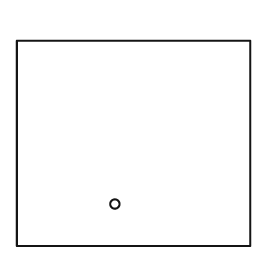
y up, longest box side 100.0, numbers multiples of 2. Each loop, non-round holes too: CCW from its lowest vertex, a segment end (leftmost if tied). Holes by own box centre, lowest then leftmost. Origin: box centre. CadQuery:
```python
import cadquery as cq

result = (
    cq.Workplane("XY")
    .moveTo(-50.0, -44.0)
    .lineTo(50.0, -44.0)
    .lineTo(50.0, 44.0)
    .lineTo(-50.0, 44.0)
    .close()
    .moveTo(-8.0, -26.0)
    .circle(2.0)
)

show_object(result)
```